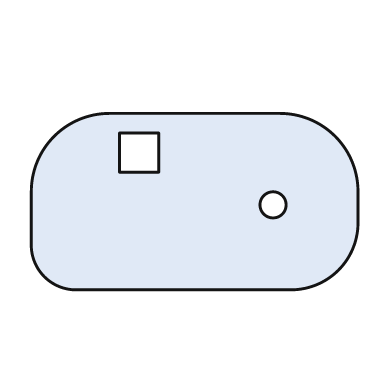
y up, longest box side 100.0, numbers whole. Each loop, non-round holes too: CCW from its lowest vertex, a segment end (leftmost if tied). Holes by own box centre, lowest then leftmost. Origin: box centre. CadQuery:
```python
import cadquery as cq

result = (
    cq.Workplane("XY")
    .moveTo(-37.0, -27.0)
    .lineTo(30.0, -27.0)
    .threePointArc((44.0, -21.0), (50.0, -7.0))
    .lineTo(50.0, 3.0)
    .threePointArc((43.0, 20.0), (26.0, 27.0))
    .lineTo(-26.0, 27.0)
    .threePointArc((-43.0, 20.0), (-50.0, 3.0))
    .lineTo(-50.0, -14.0)
    .threePointArc((-46.0, -23.0), (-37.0, -27.0))
    .close()
    .moveTo(24.0, -1.0)
    .circle(4.0)
    .moveTo(-23.0, 9.0)
    .lineTo(-11.0, 9.0)
    .lineTo(-11.0, 21.0)
    .lineTo(-23.0, 21.0)
    .close()
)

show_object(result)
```